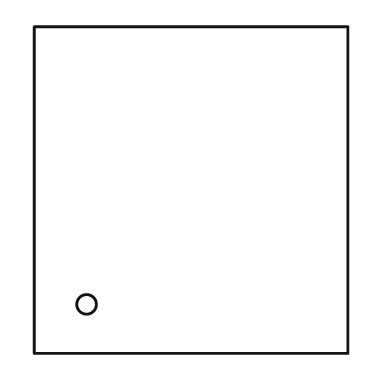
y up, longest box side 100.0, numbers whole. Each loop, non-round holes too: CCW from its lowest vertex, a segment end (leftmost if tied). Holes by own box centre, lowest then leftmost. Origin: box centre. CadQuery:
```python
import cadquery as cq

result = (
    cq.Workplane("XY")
    .moveTo(-48.0, -50.0)
    .lineTo(48.0, -50.0)
    .lineTo(48.0, 50.0)
    .lineTo(-48.0, 50.0)
    .close()
    .moveTo(-32.0, -35.0)
    .circle(3.0)
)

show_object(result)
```